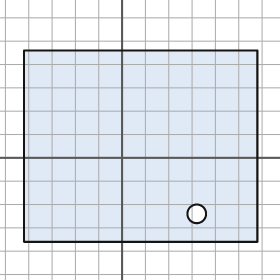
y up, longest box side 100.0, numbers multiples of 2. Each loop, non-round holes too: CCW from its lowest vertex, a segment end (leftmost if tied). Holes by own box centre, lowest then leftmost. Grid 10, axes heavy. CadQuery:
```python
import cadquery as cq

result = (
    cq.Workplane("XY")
    .moveTo(-42.0, -36.0)
    .lineTo(58.0, -36.0)
    .lineTo(58.0, 46.0)
    .lineTo(-42.0, 46.0)
    .close()
    .moveTo(32.0, -24.0)
    .circle(4.0)
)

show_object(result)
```